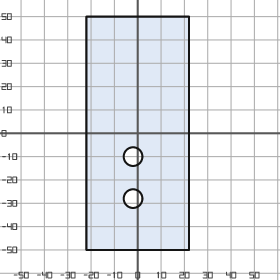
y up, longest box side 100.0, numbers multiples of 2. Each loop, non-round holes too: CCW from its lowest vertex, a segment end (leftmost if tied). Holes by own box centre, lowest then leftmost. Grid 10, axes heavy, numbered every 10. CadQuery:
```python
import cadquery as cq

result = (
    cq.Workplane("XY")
    .moveTo(-22.0, -50.0)
    .lineTo(22.0, -50.0)
    .lineTo(22.0, 50.0)
    .lineTo(-22.0, 50.0)
    .close()
    .moveTo(-2.0, -28.0)
    .circle(4.0)
    .moveTo(-2.0, -10.0)
    .circle(4.0)
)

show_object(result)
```